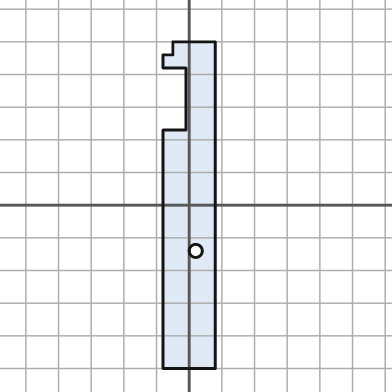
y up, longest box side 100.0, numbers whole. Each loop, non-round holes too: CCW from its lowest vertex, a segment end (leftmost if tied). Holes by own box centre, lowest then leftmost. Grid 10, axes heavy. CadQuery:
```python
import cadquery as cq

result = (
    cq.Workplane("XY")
    .moveTo(-8.0, -50.0)
    .lineTo(8.0, -50.0)
    .lineTo(8.0, 50.0)
    .lineTo(-5.0, 50.0)
    .lineTo(-5.0, 46.0)
    .lineTo(-8.0, 46.0)
    .lineTo(-8.0, 42.0)
    .lineTo(-1.0, 42.0)
    .lineTo(-1.0, 23.0)
    .lineTo(-8.0, 23.0)
    .close()
    .moveTo(2.0, -14.0)
    .circle(2.0)
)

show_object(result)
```